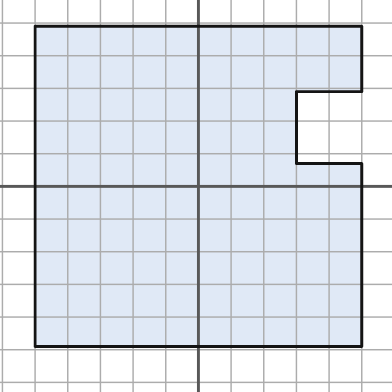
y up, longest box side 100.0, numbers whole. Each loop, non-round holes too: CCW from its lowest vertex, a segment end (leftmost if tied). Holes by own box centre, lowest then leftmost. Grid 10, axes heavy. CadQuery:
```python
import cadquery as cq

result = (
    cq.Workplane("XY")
    .moveTo(-50.0, -49.0)
    .lineTo(50.0, -49.0)
    .lineTo(50.0, 7.0)
    .lineTo(30.0, 7.0)
    .lineTo(30.0, 29.0)
    .lineTo(50.0, 29.0)
    .lineTo(50.0, 49.0)
    .lineTo(-50.0, 49.0)
    .close()
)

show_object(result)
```